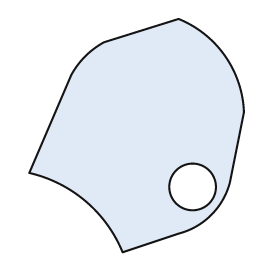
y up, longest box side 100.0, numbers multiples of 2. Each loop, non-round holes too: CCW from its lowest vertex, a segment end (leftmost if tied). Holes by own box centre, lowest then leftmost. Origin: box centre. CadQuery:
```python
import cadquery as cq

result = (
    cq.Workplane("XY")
    .moveTo(-6.0, -50.0)
    .lineTo(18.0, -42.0)
    .threePointArc((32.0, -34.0), (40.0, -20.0))
    .lineTo(46.0, 10.0)
    .threePointArc((38.0, 34.0), (18.0, 50.0))
    .lineTo(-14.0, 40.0)
    .threePointArc((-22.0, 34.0), (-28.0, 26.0))
    .lineTo(-46.0, -16.0)
    .threePointArc((-22.0, -28.0), (-6.0, -50.0))
    .close()
    .moveTo(24.0, -22.0)
    .circle(10.0)
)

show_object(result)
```